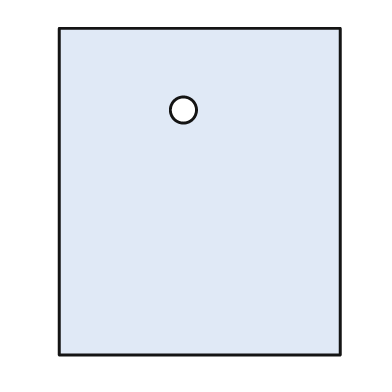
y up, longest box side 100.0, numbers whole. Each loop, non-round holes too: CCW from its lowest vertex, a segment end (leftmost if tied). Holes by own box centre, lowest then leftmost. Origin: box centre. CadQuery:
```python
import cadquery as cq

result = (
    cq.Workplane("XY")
    .moveTo(-43.0, -50.0)
    .lineTo(43.0, -50.0)
    .lineTo(43.0, 50.0)
    .lineTo(-43.0, 50.0)
    .close()
    .moveTo(-5.0, 25.0)
    .circle(4.0)
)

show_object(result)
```